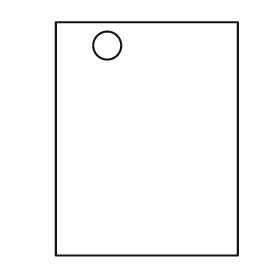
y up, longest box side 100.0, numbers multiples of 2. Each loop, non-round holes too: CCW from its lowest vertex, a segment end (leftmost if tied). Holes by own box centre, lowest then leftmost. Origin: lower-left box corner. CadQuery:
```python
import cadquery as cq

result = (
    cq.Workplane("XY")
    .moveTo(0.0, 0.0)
    .lineTo(78.0, 0.0)
    .lineTo(78.0, 100.0)
    .lineTo(0.0, 100.0)
    .close()
    .moveTo(22.0, 90.0)
    .circle(6.0)
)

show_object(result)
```